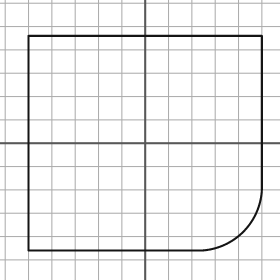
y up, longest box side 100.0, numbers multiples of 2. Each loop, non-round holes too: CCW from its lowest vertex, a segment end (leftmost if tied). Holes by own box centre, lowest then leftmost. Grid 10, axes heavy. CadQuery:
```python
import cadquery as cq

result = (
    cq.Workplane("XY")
    .moveTo(-50.0, -46.0)
    .lineTo(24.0, -46.0)
    .threePointArc((42.0, -38.0), (50.0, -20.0))
    .lineTo(50.0, 46.0)
    .lineTo(-50.0, 46.0)
    .close()
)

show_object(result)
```